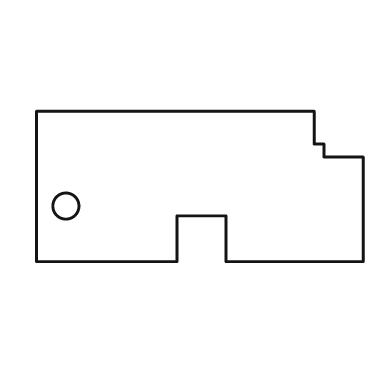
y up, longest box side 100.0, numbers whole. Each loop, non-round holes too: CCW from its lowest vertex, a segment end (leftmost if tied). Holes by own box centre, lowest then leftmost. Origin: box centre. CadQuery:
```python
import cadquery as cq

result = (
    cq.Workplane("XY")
    .moveTo(-50.0, -23.0)
    .lineTo(-7.0, -23.0)
    .lineTo(-7.0, -9.0)
    .lineTo(8.0, -9.0)
    .lineTo(8.0, -23.0)
    .lineTo(50.0, -23.0)
    .lineTo(50.0, 9.0)
    .lineTo(38.0, 9.0)
    .lineTo(38.0, 13.0)
    .lineTo(35.0, 13.0)
    .lineTo(35.0, 23.0)
    .lineTo(-50.0, 23.0)
    .close()
    .moveTo(-41.0, -6.0)
    .circle(4.0)
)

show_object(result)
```